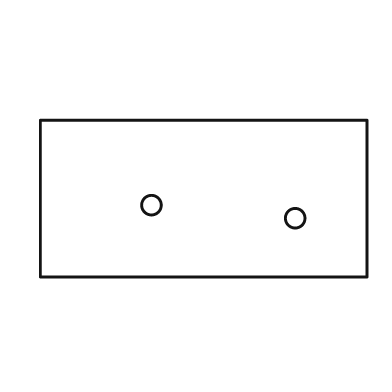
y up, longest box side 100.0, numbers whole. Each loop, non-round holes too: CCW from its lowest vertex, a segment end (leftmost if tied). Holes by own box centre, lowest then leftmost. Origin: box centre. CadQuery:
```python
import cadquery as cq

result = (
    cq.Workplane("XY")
    .moveTo(-50.0, -24.0)
    .lineTo(50.0, -24.0)
    .lineTo(50.0, 24.0)
    .lineTo(-50.0, 24.0)
    .close()
    .moveTo(28.0, -6.0)
    .circle(3.0)
    .moveTo(-16.0, -2.0)
    .circle(3.0)
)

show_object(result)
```